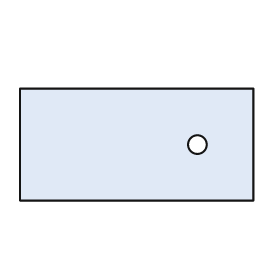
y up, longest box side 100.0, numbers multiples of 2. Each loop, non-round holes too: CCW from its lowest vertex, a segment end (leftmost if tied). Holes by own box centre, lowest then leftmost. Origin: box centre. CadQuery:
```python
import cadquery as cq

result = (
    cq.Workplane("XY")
    .moveTo(-50.0, -24.0)
    .lineTo(50.0, -24.0)
    .lineTo(50.0, 24.0)
    .lineTo(-50.0, 24.0)
    .close()
    .moveTo(26.0, 0.0)
    .circle(4.0)
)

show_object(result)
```